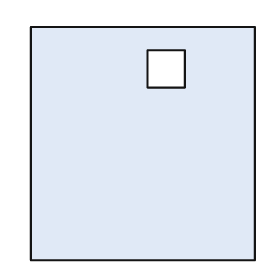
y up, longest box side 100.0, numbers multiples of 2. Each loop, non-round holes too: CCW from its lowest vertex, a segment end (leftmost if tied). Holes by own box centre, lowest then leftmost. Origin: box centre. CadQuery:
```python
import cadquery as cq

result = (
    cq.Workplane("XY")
    .moveTo(-48.0, -50.0)
    .lineTo(48.0, -50.0)
    .lineTo(48.0, 50.0)
    .lineTo(-48.0, 50.0)
    .close()
    .moveTo(2.0, 24.0)
    .lineTo(18.0, 24.0)
    .lineTo(18.0, 40.0)
    .lineTo(2.0, 40.0)
    .close()
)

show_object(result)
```